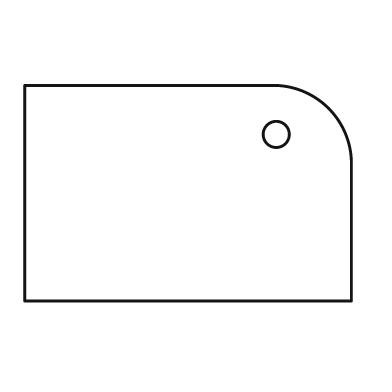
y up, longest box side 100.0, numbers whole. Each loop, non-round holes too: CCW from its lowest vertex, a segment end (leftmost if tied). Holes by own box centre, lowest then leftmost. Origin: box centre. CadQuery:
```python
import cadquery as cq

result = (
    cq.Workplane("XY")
    .moveTo(-50.0, -33.0)
    .lineTo(50.0, -33.0)
    .lineTo(50.0, 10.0)
    .threePointArc((43.0, 26.0), (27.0, 33.0))
    .lineTo(-50.0, 33.0)
    .close()
    .moveTo(27.0, 18.0)
    .circle(4.0)
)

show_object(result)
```